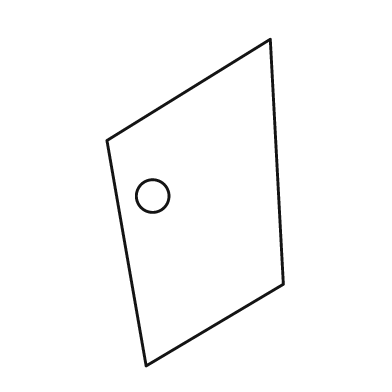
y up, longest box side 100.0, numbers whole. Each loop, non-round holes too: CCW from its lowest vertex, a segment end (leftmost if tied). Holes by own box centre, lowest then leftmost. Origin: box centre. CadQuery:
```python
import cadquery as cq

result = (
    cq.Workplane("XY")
    .moveTo(-15.0, -50.0)
    .lineTo(27.0, -25.0)
    .lineTo(23.0, 50.0)
    .lineTo(-27.0, 19.0)
    .close()
    .moveTo(-13.0, 2.0)
    .circle(5.0)
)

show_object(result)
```